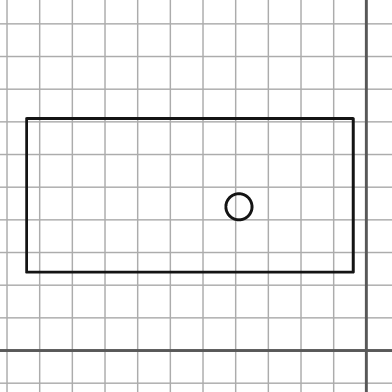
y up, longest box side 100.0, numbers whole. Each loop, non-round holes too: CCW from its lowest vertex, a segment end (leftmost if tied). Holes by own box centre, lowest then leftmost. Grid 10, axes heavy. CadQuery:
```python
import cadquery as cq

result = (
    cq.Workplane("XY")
    .moveTo(-104.0, 24.0)
    .lineTo(-4.0, 24.0)
    .lineTo(-4.0, 71.0)
    .lineTo(-104.0, 71.0)
    .close()
    .moveTo(-39.0, 44.0)
    .circle(4.0)
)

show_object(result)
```